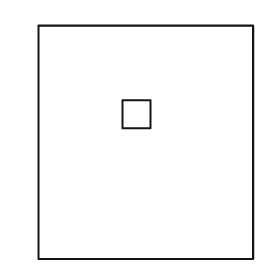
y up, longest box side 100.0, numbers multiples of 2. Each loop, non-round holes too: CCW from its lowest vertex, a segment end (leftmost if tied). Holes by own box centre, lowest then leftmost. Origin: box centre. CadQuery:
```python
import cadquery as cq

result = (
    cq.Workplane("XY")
    .moveTo(-46.0, -50.0)
    .lineTo(46.0, -50.0)
    .lineTo(46.0, 50.0)
    .lineTo(-46.0, 50.0)
    .close()
    .moveTo(-10.0, 6.0)
    .lineTo(2.0, 6.0)
    .lineTo(2.0, 18.0)
    .lineTo(-10.0, 18.0)
    .close()
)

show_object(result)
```